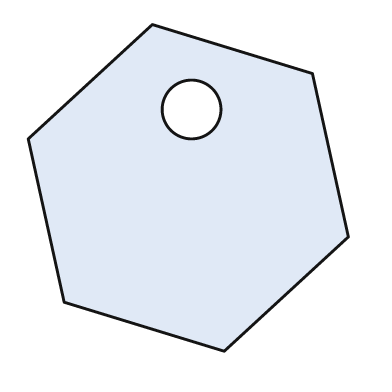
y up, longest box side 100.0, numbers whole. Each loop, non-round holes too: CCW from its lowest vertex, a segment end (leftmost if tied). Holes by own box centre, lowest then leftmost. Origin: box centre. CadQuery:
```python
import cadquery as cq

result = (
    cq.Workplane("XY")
    .moveTo(11.0, -50.0)
    .lineTo(49.0, -15.0)
    .lineTo(38.0, 35.0)
    .lineTo(-11.0, 50.0)
    .lineTo(-49.0, 15.0)
    .lineTo(-38.0, -35.0)
    .close()
    .moveTo(1.0, 24.0)
    .circle(9.0)
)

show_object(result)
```